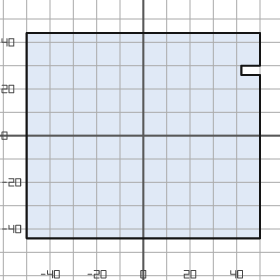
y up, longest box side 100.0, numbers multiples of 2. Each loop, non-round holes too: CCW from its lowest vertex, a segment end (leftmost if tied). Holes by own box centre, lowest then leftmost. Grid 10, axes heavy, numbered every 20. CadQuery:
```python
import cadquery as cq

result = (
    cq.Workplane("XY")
    .moveTo(-50.0, -44.0)
    .lineTo(50.0, -44.0)
    .lineTo(50.0, 26.0)
    .lineTo(42.0, 26.0)
    .lineTo(42.0, 30.0)
    .lineTo(50.0, 30.0)
    .lineTo(50.0, 44.0)
    .lineTo(-50.0, 44.0)
    .close()
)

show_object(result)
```